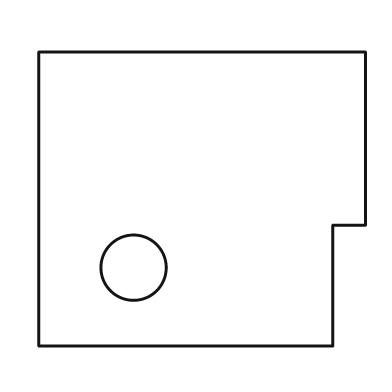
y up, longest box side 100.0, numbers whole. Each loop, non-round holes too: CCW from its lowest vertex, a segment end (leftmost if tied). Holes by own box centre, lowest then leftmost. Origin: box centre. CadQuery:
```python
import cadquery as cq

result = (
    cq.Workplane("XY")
    .moveTo(-50.0, -45.0)
    .lineTo(40.0, -45.0)
    .lineTo(40.0, -8.0)
    .lineTo(50.0, -8.0)
    .lineTo(50.0, 45.0)
    .lineTo(-50.0, 45.0)
    .close()
    .moveTo(-21.0, -21.0)
    .circle(10.0)
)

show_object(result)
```